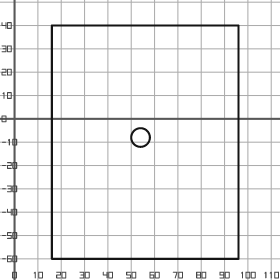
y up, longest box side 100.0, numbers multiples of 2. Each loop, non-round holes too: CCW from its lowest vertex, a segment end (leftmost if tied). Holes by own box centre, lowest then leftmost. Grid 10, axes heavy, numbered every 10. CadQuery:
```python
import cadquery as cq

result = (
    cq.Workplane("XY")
    .moveTo(16.0, -60.0)
    .lineTo(96.0, -60.0)
    .lineTo(96.0, 40.0)
    .lineTo(16.0, 40.0)
    .close()
    .moveTo(54.0, -8.0)
    .circle(4.0)
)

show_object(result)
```